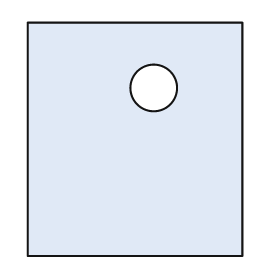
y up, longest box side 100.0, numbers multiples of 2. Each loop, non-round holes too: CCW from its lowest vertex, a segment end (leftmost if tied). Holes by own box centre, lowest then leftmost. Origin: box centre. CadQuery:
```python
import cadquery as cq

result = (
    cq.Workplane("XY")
    .moveTo(-46.0, -50.0)
    .lineTo(46.0, -50.0)
    .lineTo(46.0, 50.0)
    .lineTo(-46.0, 50.0)
    .close()
    .moveTo(8.0, 22.0)
    .circle(10.0)
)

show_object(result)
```